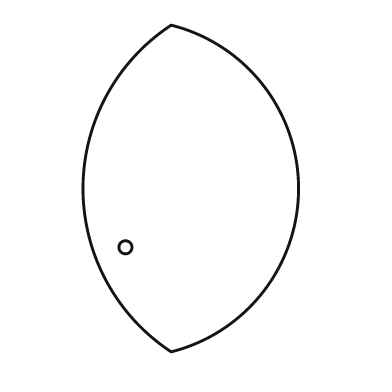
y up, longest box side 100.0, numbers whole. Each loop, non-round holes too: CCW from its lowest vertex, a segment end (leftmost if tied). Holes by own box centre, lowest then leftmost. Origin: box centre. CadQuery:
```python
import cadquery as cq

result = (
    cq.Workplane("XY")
    .moveTo(-6.0, -50.0)
    .threePointArc((33.0, 0.0), (-6.0, 50.0))
    .threePointArc((-33.0, 0.0), (-6.0, -50.0))
    .close()
    .moveTo(-20.0, -18.0)
    .circle(2.0)
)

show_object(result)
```